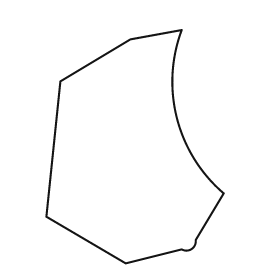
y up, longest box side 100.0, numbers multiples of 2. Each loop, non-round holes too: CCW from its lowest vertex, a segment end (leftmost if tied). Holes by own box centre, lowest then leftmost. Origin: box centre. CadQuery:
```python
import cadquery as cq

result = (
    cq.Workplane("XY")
    .moveTo(-4.0, -50.0)
    .lineTo(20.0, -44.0)
    .threePointArc((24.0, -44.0), (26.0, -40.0))
    .lineTo(38.0, -20.0)
    .threePointArc((18.0, 12.0), (20.0, 50.0))
    .lineTo(-2.0, 46.0)
    .lineTo(-32.0, 28.0)
    .lineTo(-38.0, -30.0)
    .close()
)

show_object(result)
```